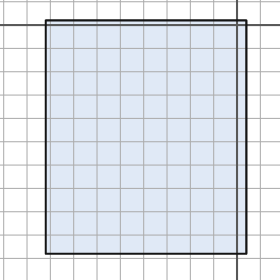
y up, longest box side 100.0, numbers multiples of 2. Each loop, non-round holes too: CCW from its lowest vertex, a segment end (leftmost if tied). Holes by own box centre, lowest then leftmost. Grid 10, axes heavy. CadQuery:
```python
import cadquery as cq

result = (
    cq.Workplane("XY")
    .moveTo(-82.0, -98.0)
    .lineTo(4.0, -98.0)
    .lineTo(4.0, 2.0)
    .lineTo(-82.0, 2.0)
    .close()
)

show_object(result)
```